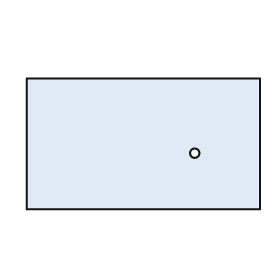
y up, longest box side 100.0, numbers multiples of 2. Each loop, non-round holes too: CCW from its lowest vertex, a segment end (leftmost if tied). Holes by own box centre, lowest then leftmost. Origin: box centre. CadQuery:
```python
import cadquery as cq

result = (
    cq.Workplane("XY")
    .moveTo(-50.0, -28.0)
    .lineTo(50.0, -28.0)
    .lineTo(50.0, 28.0)
    .lineTo(-50.0, 28.0)
    .close()
    .moveTo(22.0, -4.0)
    .circle(2.0)
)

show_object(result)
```